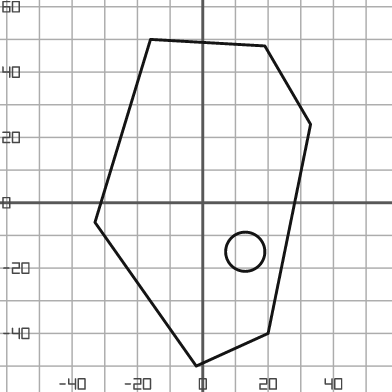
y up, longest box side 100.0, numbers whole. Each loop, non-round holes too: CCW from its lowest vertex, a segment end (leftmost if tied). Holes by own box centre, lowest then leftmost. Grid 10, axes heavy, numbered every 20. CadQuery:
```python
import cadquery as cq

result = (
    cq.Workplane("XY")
    .moveTo(-2.0, -50.0)
    .lineTo(20.0, -40.0)
    .lineTo(33.0, 24.0)
    .lineTo(19.0, 48.0)
    .lineTo(-16.0, 50.0)
    .lineTo(-33.0, -6.0)
    .close()
    .moveTo(13.0, -15.0)
    .circle(6.0)
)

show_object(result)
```